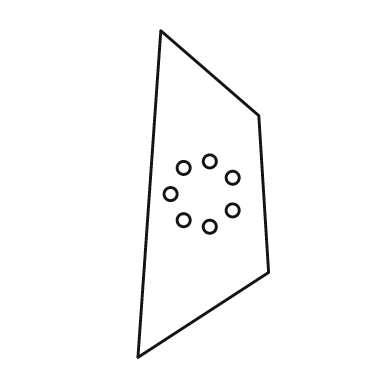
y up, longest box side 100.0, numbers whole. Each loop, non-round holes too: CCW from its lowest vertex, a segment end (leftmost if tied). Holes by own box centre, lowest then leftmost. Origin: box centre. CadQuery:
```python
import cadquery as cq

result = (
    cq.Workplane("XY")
    .moveTo(-20.0, -50.0)
    .lineTo(20.0, -24.0)
    .lineTo(17.0, 24.0)
    .lineTo(-13.0, 50.0)
    .close()
    .moveTo(2.0, -10.0)
    .circle(2.0)
    .moveTo(-6.0, -8.0)
    .circle(2.0)
    .moveTo(9.0, -5.0)
    .circle(2.0)
    .moveTo(-10.0, 0.0)
    .circle(2.0)
    .moveTo(9.0, 5.0)
    .circle(2.0)
    .moveTo(-6.0, 8.0)
    .circle(2.0)
    .moveTo(2.0, 10.0)
    .circle(2.0)
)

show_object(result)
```